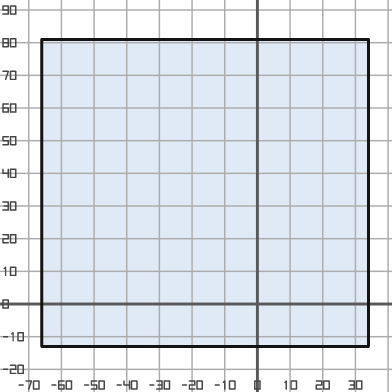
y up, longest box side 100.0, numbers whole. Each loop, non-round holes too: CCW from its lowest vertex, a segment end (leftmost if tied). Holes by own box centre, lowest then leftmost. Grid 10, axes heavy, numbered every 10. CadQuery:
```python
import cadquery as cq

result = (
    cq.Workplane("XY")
    .moveTo(-66.0, -13.0)
    .lineTo(34.0, -13.0)
    .lineTo(34.0, 81.0)
    .lineTo(-66.0, 81.0)
    .close()
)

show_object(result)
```